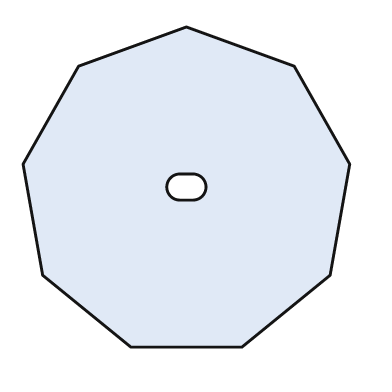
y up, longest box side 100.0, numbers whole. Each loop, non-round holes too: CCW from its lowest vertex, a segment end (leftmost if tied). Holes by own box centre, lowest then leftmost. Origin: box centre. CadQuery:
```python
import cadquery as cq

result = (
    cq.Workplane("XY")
    .moveTo(-17.0, -49.0)
    .lineTo(17.0, -49.0)
    .lineTo(44.0, -27.0)
    .lineTo(50.0, 7.0)
    .lineTo(33.0, 37.0)
    .lineTo(0.0, 49.0)
    .lineTo(-33.0, 37.0)
    .lineTo(-50.0, 7.0)
    .lineTo(-44.0, -27.0)
    .close()
    .moveTo(-2.0, -4.0)
    .lineTo(2.0, -4.0)
    .threePointArc((6.0, 0.0), (2.0, 4.0))
    .lineTo(-2.0, 4.0)
    .threePointArc((-6.0, 0.0), (-2.0, -4.0))
    .close()
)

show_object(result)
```